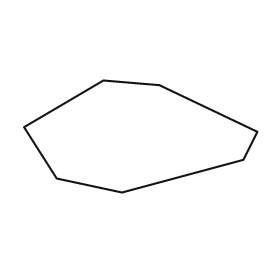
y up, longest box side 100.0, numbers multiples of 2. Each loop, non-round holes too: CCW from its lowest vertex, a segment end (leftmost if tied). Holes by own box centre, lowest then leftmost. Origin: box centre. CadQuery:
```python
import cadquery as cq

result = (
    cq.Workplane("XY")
    .moveTo(-8.0, -24.0)
    .lineTo(44.0, -10.0)
    .lineTo(50.0, 2.0)
    .lineTo(8.0, 22.0)
    .lineTo(-16.0, 24.0)
    .lineTo(-50.0, 4.0)
    .lineTo(-36.0, -18.0)
    .close()
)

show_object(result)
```